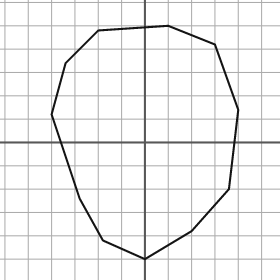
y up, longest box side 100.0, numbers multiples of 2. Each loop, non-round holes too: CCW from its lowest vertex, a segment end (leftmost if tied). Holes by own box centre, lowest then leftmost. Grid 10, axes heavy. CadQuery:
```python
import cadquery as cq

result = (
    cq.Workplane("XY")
    .moveTo(0.0, -50.0)
    .lineTo(20.0, -38.0)
    .lineTo(36.0, -20.0)
    .lineTo(40.0, 14.0)
    .lineTo(30.0, 42.0)
    .lineTo(10.0, 50.0)
    .lineTo(-20.0, 48.0)
    .lineTo(-34.0, 34.0)
    .lineTo(-40.0, 12.0)
    .lineTo(-28.0, -24.0)
    .lineTo(-18.0, -42.0)
    .close()
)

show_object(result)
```